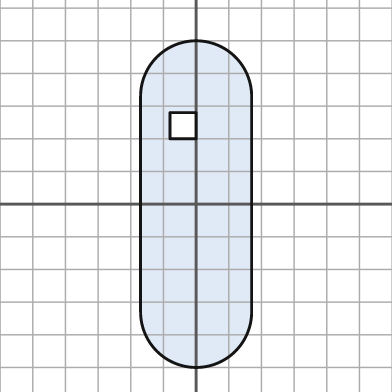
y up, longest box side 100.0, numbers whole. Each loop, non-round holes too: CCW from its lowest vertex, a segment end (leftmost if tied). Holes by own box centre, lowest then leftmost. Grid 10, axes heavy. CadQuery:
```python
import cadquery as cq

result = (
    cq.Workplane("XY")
    .moveTo(-17.0, -33.0)
    .threePointArc((0.0, -50.0), (17.0, -33.0))
    .lineTo(17.0, 33.0)
    .threePointArc((0.0, 50.0), (-17.0, 33.0))
    .close()
    .moveTo(-8.0, 20.0)
    .lineTo(0.0, 20.0)
    .lineTo(0.0, 28.0)
    .lineTo(-8.0, 28.0)
    .close()
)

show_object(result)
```